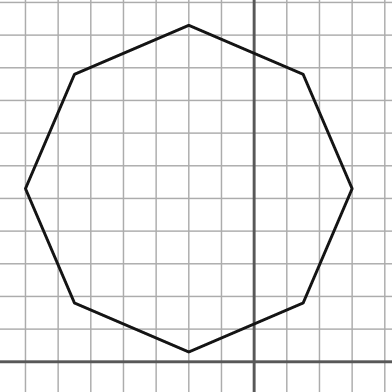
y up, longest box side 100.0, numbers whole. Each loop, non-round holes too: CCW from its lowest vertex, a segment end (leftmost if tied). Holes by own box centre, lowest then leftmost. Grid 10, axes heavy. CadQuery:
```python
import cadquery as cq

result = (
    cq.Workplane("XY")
    .moveTo(-20.0, 3.0)
    .lineTo(15.0, 18.0)
    .lineTo(30.0, 53.0)
    .lineTo(15.0, 88.0)
    .lineTo(-20.0, 103.0)
    .lineTo(-55.0, 88.0)
    .lineTo(-70.0, 53.0)
    .lineTo(-55.0, 18.0)
    .close()
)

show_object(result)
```